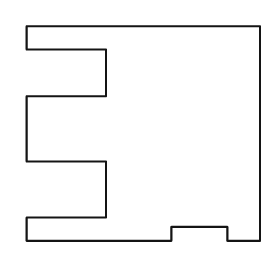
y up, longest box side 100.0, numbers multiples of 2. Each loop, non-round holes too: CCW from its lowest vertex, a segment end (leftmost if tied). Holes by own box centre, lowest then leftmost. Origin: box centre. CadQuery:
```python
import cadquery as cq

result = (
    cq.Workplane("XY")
    .moveTo(-50.0, -46.0)
    .lineTo(12.0, -46.0)
    .lineTo(12.0, -40.0)
    .lineTo(36.0, -40.0)
    .lineTo(36.0, -46.0)
    .lineTo(50.0, -46.0)
    .lineTo(50.0, 46.0)
    .lineTo(-50.0, 46.0)
    .lineTo(-50.0, 36.0)
    .lineTo(-16.0, 36.0)
    .lineTo(-16.0, 16.0)
    .lineTo(-50.0, 16.0)
    .lineTo(-50.0, -12.0)
    .lineTo(-16.0, -12.0)
    .lineTo(-16.0, -36.0)
    .lineTo(-50.0, -36.0)
    .close()
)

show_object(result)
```